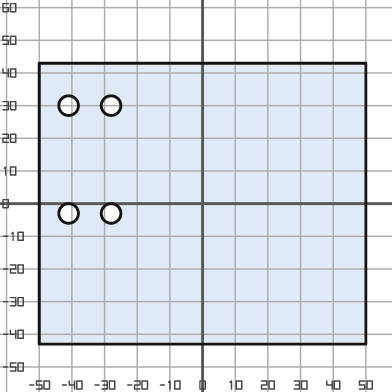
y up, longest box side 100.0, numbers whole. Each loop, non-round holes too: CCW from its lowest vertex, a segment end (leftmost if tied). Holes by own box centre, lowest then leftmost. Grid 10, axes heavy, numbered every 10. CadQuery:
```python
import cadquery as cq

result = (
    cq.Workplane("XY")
    .moveTo(-50.0, -43.0)
    .lineTo(50.0, -43.0)
    .lineTo(50.0, 43.0)
    .lineTo(-50.0, 43.0)
    .close()
    .moveTo(-41.0, -3.0)
    .circle(3.0)
    .moveTo(-28.0, -3.0)
    .circle(3.0)
    .moveTo(-41.0, 30.0)
    .circle(3.0)
    .moveTo(-28.0, 30.0)
    .circle(3.0)
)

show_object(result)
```